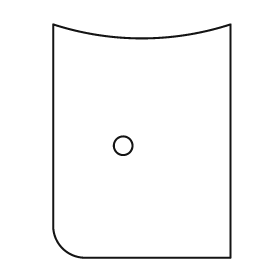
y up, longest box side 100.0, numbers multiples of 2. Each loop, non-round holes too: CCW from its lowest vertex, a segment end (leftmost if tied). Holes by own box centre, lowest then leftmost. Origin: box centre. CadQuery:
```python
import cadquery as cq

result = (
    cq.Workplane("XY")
    .moveTo(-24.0, -50.0)
    .lineTo(38.0, -50.0)
    .lineTo(38.0, 50.0)
    .threePointArc((0.0, 44.0), (-38.0, 50.0))
    .lineTo(-38.0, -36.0)
    .threePointArc((-34.0, -46.0), (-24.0, -50.0))
    .close()
    .moveTo(-8.0, -2.0)
    .circle(4.0)
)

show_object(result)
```